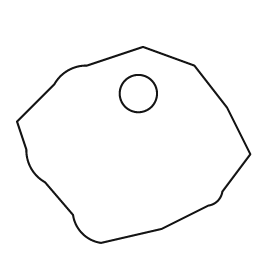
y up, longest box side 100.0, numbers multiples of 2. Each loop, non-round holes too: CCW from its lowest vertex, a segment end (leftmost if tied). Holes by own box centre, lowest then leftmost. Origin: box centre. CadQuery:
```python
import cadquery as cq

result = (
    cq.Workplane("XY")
    .moveTo(-14.0, -42.0)
    .lineTo(12.0, -36.0)
    .lineTo(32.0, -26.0)
    .threePointArc((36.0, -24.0), (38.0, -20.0))
    .lineTo(50.0, -4.0)
    .lineTo(40.0, 16.0)
    .lineTo(26.0, 34.0)
    .lineTo(4.0, 42.0)
    .lineTo(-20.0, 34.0)
    .threePointArc((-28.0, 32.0), (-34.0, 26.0))
    .lineTo(-50.0, 10.0)
    .lineTo(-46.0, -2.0)
    .threePointArc((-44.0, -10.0), (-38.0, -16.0))
    .lineTo(-26.0, -30.0)
    .threePointArc((-22.0, -38.0), (-14.0, -42.0))
    .close()
    .moveTo(2.0, 22.0)
    .circle(8.0)
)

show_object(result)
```